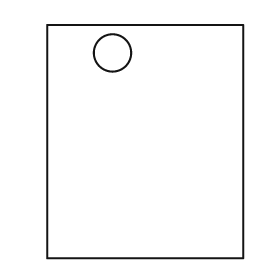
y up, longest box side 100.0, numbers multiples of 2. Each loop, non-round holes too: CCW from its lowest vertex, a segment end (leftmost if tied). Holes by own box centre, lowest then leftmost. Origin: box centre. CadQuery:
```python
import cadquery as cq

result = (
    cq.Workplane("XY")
    .moveTo(-42.0, -50.0)
    .lineTo(42.0, -50.0)
    .lineTo(42.0, 50.0)
    .lineTo(-42.0, 50.0)
    .close()
    .moveTo(-14.0, 38.0)
    .circle(8.0)
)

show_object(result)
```